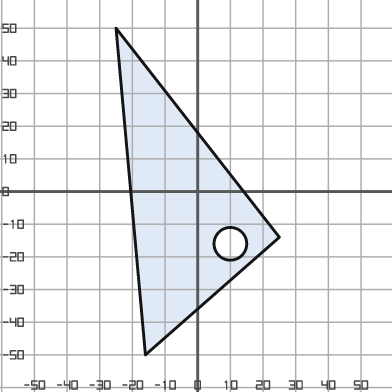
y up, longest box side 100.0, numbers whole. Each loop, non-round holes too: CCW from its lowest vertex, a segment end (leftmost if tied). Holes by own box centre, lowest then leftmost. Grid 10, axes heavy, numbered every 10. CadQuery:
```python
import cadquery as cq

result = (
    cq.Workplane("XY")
    .moveTo(-16.0, -50.0)
    .lineTo(25.0, -14.0)
    .lineTo(-25.0, 50.0)
    .close()
    .moveTo(10.0, -16.0)
    .circle(5.0)
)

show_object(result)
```